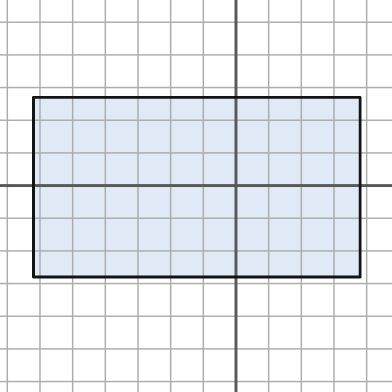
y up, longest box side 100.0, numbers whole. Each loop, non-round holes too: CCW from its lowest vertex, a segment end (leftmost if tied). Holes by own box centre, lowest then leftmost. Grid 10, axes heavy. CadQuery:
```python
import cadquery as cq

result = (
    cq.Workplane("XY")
    .moveTo(-62.0, -28.0)
    .lineTo(38.0, -28.0)
    .lineTo(38.0, 27.0)
    .lineTo(-62.0, 27.0)
    .close()
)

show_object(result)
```